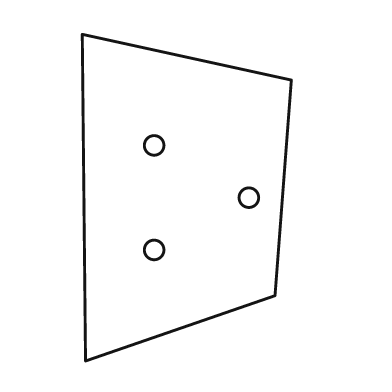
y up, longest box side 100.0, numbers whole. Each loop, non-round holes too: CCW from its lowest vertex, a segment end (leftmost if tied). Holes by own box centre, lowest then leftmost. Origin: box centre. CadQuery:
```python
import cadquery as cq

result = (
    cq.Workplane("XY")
    .moveTo(-31.0, -50.0)
    .lineTo(27.0, -30.0)
    .lineTo(32.0, 36.0)
    .lineTo(-32.0, 50.0)
    .close()
    .moveTo(-10.0, -16.0)
    .circle(3.0)
    .moveTo(19.0, 0.0)
    .circle(3.0)
    .moveTo(-10.0, 16.0)
    .circle(3.0)
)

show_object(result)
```